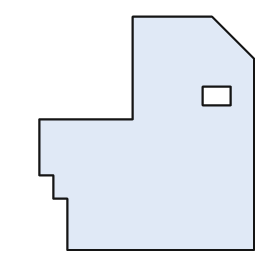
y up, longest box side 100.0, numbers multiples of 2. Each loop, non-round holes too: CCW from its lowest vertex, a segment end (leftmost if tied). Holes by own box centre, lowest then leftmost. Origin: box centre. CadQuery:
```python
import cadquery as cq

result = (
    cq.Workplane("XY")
    .moveTo(-34.0, -50.0)
    .lineTo(46.0, -50.0)
    .lineTo(46.0, 32.0)
    .lineTo(28.0, 50.0)
    .lineTo(-6.0, 50.0)
    .lineTo(-6.0, 6.0)
    .lineTo(-46.0, 6.0)
    .lineTo(-46.0, -18.0)
    .lineTo(-40.0, -18.0)
    .lineTo(-40.0, -28.0)
    .lineTo(-34.0, -28.0)
    .close()
    .moveTo(24.0, 12.0)
    .lineTo(36.0, 12.0)
    .lineTo(36.0, 20.0)
    .lineTo(24.0, 20.0)
    .close()
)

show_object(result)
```